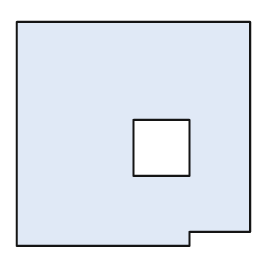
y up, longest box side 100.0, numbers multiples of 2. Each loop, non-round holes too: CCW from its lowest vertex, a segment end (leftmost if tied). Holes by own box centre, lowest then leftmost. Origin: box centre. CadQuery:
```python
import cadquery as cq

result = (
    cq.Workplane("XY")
    .moveTo(-50.0, -48.0)
    .lineTo(24.0, -48.0)
    .lineTo(24.0, -42.0)
    .lineTo(50.0, -42.0)
    .lineTo(50.0, 48.0)
    .lineTo(-50.0, 48.0)
    .close()
    .moveTo(0.0, -18.0)
    .lineTo(24.0, -18.0)
    .lineTo(24.0, 6.0)
    .lineTo(0.0, 6.0)
    .close()
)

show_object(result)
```